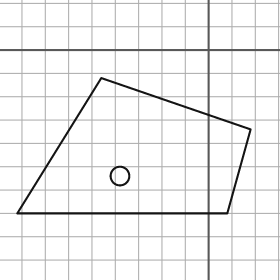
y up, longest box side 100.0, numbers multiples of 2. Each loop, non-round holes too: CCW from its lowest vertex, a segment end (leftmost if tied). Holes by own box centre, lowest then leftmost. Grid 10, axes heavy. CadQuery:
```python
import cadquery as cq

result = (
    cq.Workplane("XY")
    .moveTo(-82.0, -70.0)
    .lineTo(8.0, -70.0)
    .lineTo(18.0, -34.0)
    .lineTo(-46.0, -12.0)
    .close()
    .moveTo(-38.0, -54.0)
    .circle(4.0)
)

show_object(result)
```